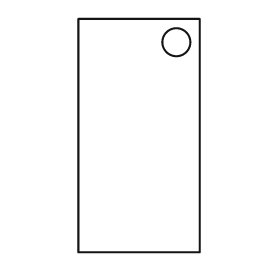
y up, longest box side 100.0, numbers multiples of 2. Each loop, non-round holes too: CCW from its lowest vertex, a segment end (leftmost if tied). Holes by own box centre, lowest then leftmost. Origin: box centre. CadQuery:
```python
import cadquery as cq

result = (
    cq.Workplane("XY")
    .moveTo(-26.0, -50.0)
    .lineTo(26.0, -50.0)
    .lineTo(26.0, 50.0)
    .lineTo(-26.0, 50.0)
    .close()
    .moveTo(16.0, 40.0)
    .circle(6.0)
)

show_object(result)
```